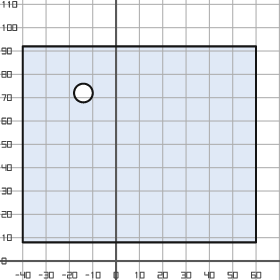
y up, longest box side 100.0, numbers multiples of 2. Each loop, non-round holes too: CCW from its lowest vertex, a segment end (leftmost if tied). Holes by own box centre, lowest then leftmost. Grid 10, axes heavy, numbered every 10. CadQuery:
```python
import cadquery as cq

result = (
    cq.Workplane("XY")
    .moveTo(-40.0, 8.0)
    .lineTo(60.0, 8.0)
    .lineTo(60.0, 92.0)
    .lineTo(-40.0, 92.0)
    .close()
    .moveTo(-14.0, 72.0)
    .circle(4.0)
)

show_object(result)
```